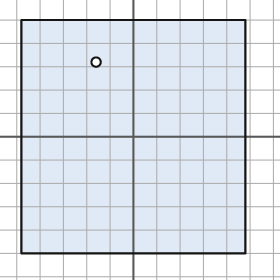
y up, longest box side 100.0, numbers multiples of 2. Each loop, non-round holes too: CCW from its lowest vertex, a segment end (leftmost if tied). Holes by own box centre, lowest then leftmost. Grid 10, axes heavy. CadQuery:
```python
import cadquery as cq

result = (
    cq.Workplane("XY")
    .moveTo(-48.0, -50.0)
    .lineTo(48.0, -50.0)
    .lineTo(48.0, 50.0)
    .lineTo(-48.0, 50.0)
    .close()
    .moveTo(-16.0, 32.0)
    .circle(2.0)
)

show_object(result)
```